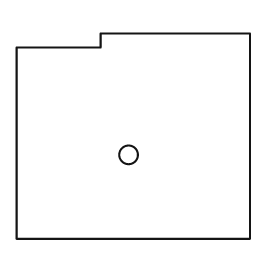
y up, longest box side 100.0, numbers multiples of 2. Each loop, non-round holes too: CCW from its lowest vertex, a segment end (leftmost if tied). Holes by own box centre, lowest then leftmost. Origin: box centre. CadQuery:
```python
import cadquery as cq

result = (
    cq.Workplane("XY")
    .moveTo(-50.0, -44.0)
    .lineTo(50.0, -44.0)
    .lineTo(50.0, 44.0)
    .lineTo(-14.0, 44.0)
    .lineTo(-14.0, 38.0)
    .lineTo(-50.0, 38.0)
    .close()
    .moveTo(-2.0, -8.0)
    .circle(4.0)
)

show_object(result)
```